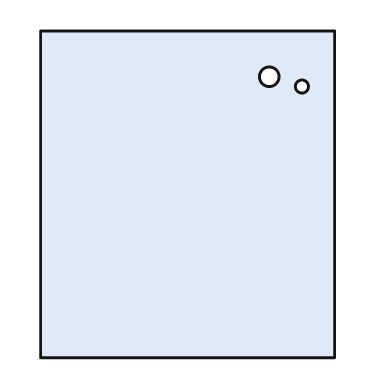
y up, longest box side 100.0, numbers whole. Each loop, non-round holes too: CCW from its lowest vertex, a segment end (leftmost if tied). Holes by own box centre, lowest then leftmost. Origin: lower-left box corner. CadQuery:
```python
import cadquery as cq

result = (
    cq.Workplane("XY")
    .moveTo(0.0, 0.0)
    .lineTo(90.0, 0.0)
    .lineTo(90.0, 100.0)
    .lineTo(0.0, 100.0)
    .close()
    .moveTo(80.0, 83.0)
    .circle(2.0)
    .moveTo(70.0, 86.0)
    .circle(3.0)
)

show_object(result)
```